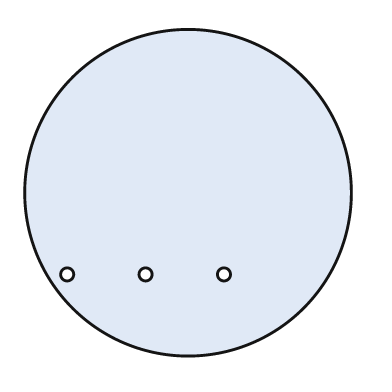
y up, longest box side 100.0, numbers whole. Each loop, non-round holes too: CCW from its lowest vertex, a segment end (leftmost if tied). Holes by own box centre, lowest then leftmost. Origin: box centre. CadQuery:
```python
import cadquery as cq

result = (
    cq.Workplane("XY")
    .moveTo(0.0, 0.0)
    .circle(50.0)
    .moveTo(-37.0, -25.0)
    .circle(2.0)
    .moveTo(-13.0, -25.0)
    .circle(2.0)
    .moveTo(11.0, -25.0)
    .circle(2.0)
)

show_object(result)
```